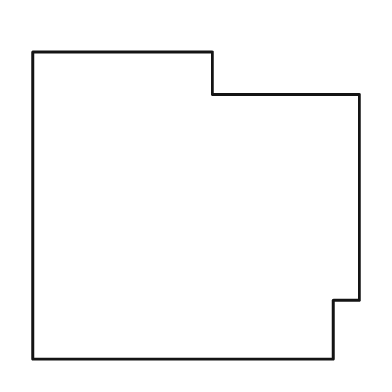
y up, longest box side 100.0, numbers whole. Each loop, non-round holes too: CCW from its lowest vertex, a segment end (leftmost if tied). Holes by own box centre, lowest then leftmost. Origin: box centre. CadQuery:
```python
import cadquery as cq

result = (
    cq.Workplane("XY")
    .moveTo(-50.0, -47.0)
    .lineTo(42.0, -47.0)
    .lineTo(42.0, -29.0)
    .lineTo(50.0, -29.0)
    .lineTo(50.0, 34.0)
    .lineTo(5.0, 34.0)
    .lineTo(5.0, 47.0)
    .lineTo(-50.0, 47.0)
    .close()
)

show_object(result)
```